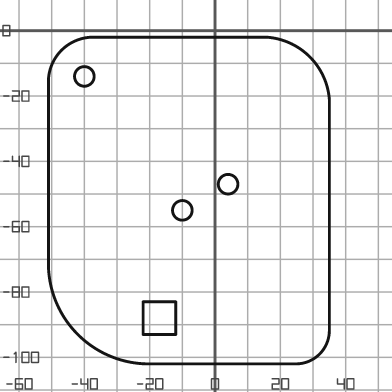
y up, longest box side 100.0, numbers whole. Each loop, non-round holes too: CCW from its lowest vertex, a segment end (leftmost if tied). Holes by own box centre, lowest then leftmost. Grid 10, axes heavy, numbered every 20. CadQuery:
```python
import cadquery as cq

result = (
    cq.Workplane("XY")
    .moveTo(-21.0, -102.0)
    .lineTo(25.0, -102.0)
    .threePointArc((32.0, -99.0), (35.0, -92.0))
    .lineTo(35.0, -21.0)
    .threePointArc((29.0, -8.0), (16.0, -2.0))
    .lineTo(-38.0, -2.0)
    .threePointArc((-47.0, -6.0), (-51.0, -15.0))
    .lineTo(-51.0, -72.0)
    .threePointArc((-42.0, -93.0), (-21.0, -102.0))
    .close()
    .moveTo(-22.0, -93.0)
    .lineTo(-12.0, -93.0)
    .lineTo(-12.0, -83.0)
    .lineTo(-22.0, -83.0)
    .close()
    .moveTo(-10.0, -55.0)
    .circle(3.0)
    .moveTo(4.0, -47.0)
    .circle(3.0)
    .moveTo(-40.0, -14.0)
    .circle(3.0)
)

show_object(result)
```